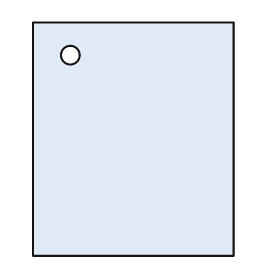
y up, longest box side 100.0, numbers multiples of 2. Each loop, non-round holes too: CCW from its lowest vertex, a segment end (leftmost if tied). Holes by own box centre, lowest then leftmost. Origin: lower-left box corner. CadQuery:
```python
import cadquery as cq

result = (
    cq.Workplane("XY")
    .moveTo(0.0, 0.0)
    .lineTo(86.0, 0.0)
    .lineTo(86.0, 100.0)
    .lineTo(0.0, 100.0)
    .close()
    .moveTo(16.0, 86.0)
    .circle(4.0)
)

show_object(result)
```